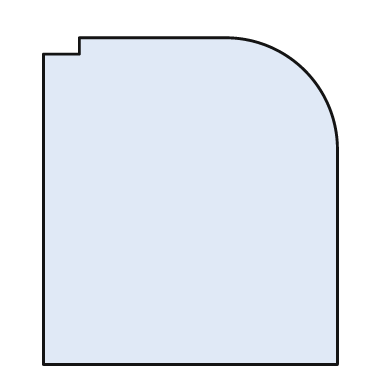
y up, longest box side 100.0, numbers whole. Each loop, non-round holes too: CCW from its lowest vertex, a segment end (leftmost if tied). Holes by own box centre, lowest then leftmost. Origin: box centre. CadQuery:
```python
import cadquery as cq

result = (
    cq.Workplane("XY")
    .moveTo(-45.0, -50.0)
    .lineTo(45.0, -50.0)
    .lineTo(45.0, 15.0)
    .threePointArc((35.0, 40.0), (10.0, 50.0))
    .lineTo(-34.0, 50.0)
    .lineTo(-34.0, 45.0)
    .lineTo(-45.0, 45.0)
    .close()
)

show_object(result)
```